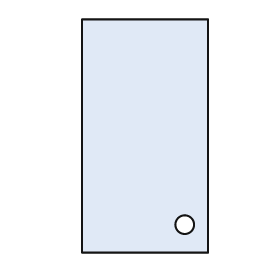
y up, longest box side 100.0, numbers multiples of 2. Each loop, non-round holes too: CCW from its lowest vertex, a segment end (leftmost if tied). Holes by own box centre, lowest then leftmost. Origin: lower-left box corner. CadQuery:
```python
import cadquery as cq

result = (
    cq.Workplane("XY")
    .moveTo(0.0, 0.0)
    .lineTo(54.0, 0.0)
    .lineTo(54.0, 100.0)
    .lineTo(0.0, 100.0)
    .close()
    .moveTo(44.0, 12.0)
    .circle(4.0)
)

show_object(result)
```